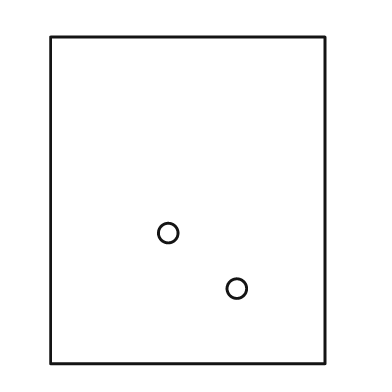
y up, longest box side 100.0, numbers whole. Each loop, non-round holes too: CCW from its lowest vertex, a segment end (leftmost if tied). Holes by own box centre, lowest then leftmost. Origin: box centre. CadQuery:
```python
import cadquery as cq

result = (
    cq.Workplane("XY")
    .moveTo(-42.0, -50.0)
    .lineTo(42.0, -50.0)
    .lineTo(42.0, 50.0)
    .lineTo(-42.0, 50.0)
    .close()
    .moveTo(15.0, -27.0)
    .circle(3.0)
    .moveTo(-6.0, -10.0)
    .circle(3.0)
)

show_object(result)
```